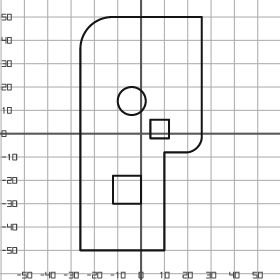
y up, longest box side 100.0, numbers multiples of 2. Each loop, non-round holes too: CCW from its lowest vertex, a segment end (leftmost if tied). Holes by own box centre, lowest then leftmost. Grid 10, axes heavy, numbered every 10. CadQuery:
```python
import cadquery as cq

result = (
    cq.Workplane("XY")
    .moveTo(-26.0, -50.0)
    .lineTo(10.0, -50.0)
    .lineTo(10.0, -8.0)
    .lineTo(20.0, -8.0)
    .threePointArc((24.0, -6.0), (26.0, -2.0))
    .lineTo(26.0, 50.0)
    .lineTo(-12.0, 50.0)
    .threePointArc((-22.0, 46.0), (-26.0, 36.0))
    .close()
    .moveTo(-12.0, -30.0)
    .lineTo(0.0, -30.0)
    .lineTo(0.0, -18.0)
    .lineTo(-12.0, -18.0)
    .close()
    .moveTo(4.0, -2.0)
    .lineTo(12.0, -2.0)
    .lineTo(12.0, 6.0)
    .lineTo(4.0, 6.0)
    .close()
    .moveTo(-4.0, 14.0)
    .circle(6.0)
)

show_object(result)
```